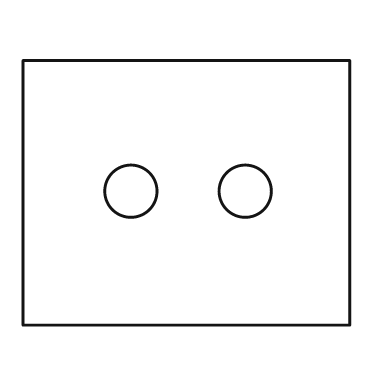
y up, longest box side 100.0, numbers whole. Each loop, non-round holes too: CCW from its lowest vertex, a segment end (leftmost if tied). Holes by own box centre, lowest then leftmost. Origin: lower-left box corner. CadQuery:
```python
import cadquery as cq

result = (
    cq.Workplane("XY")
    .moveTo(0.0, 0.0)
    .lineTo(100.0, 0.0)
    .lineTo(100.0, 81.0)
    .lineTo(0.0, 81.0)
    .close()
    .moveTo(33.0, 41.0)
    .circle(8.0)
    .moveTo(68.0, 41.0)
    .circle(8.0)
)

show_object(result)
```